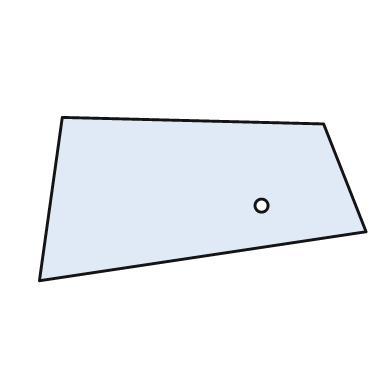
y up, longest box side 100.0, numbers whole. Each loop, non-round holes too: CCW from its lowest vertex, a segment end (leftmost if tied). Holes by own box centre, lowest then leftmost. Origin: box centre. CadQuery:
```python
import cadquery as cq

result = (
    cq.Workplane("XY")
    .moveTo(-50.0, -25.0)
    .lineTo(50.0, -10.0)
    .lineTo(37.0, 23.0)
    .lineTo(-43.0, 25.0)
    .close()
    .moveTo(18.0, -2.0)
    .circle(2.0)
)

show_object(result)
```